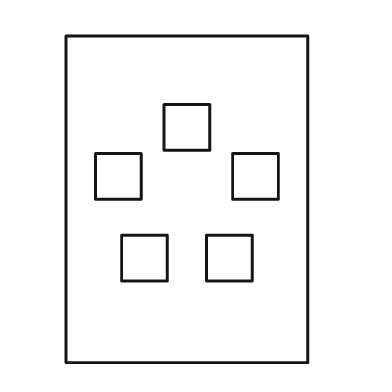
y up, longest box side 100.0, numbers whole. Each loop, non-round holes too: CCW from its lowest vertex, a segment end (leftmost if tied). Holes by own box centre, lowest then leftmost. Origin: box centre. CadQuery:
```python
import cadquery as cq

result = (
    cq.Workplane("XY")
    .moveTo(-37.0, -50.0)
    .lineTo(37.0, -50.0)
    .lineTo(37.0, 50.0)
    .lineTo(-37.0, 50.0)
    .close()
    .moveTo(-20.0, -25.0)
    .lineTo(-6.0, -25.0)
    .lineTo(-6.0, -11.0)
    .lineTo(-20.0, -11.0)
    .close()
    .moveTo(6.0, -25.0)
    .lineTo(20.0, -25.0)
    .lineTo(20.0, -11.0)
    .lineTo(6.0, -11.0)
    .close()
    .moveTo(-28.0, 0.0)
    .lineTo(-14.0, 0.0)
    .lineTo(-14.0, 14.0)
    .lineTo(-28.0, 14.0)
    .close()
    .moveTo(14.0, 0.0)
    .lineTo(28.0, 0.0)
    .lineTo(28.0, 14.0)
    .lineTo(14.0, 14.0)
    .close()
    .moveTo(-7.0, 15.0)
    .lineTo(7.0, 15.0)
    .lineTo(7.0, 29.0)
    .lineTo(-7.0, 29.0)
    .close()
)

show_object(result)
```